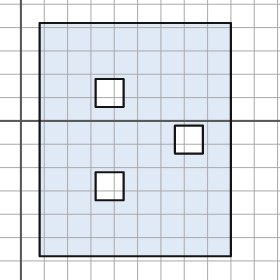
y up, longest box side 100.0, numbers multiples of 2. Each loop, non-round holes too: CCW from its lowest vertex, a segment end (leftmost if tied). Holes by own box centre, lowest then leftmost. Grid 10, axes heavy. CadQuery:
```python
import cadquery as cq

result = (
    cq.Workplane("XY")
    .moveTo(8.0, -58.0)
    .lineTo(90.0, -58.0)
    .lineTo(90.0, 42.0)
    .lineTo(8.0, 42.0)
    .close()
    .moveTo(32.0, -34.0)
    .lineTo(44.0, -34.0)
    .lineTo(44.0, -22.0)
    .lineTo(32.0, -22.0)
    .close()
    .moveTo(66.0, -14.0)
    .lineTo(78.0, -14.0)
    .lineTo(78.0, -2.0)
    .lineTo(66.0, -2.0)
    .close()
    .moveTo(32.0, 6.0)
    .lineTo(44.0, 6.0)
    .lineTo(44.0, 18.0)
    .lineTo(32.0, 18.0)
    .close()
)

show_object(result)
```